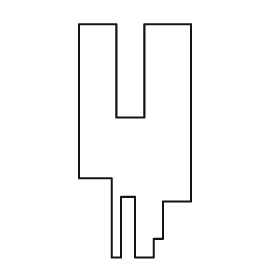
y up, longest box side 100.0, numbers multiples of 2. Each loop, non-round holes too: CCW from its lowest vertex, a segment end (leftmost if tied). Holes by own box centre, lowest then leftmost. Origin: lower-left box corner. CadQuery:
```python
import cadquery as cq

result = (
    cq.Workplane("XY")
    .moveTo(14.0, 0.0)
    .lineTo(18.0, 0.0)
    .lineTo(18.0, 26.0)
    .lineTo(24.0, 26.0)
    .lineTo(24.0, 0.0)
    .lineTo(32.0, 0.0)
    .lineTo(32.0, 8.0)
    .lineTo(36.0, 8.0)
    .lineTo(36.0, 24.0)
    .lineTo(48.0, 24.0)
    .lineTo(48.0, 100.0)
    .lineTo(28.0, 100.0)
    .lineTo(28.0, 60.0)
    .lineTo(16.0, 60.0)
    .lineTo(16.0, 100.0)
    .lineTo(0.0, 100.0)
    .lineTo(0.0, 34.0)
    .lineTo(14.0, 34.0)
    .close()
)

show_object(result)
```